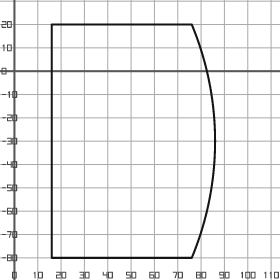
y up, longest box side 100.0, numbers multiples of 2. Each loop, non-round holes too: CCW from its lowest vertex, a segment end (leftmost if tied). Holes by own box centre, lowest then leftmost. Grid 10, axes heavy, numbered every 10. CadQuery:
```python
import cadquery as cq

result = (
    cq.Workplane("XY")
    .moveTo(16.0, -80.0)
    .lineTo(76.0, -80.0)
    .threePointArc((86.0, -30.0), (76.0, 20.0))
    .lineTo(16.0, 20.0)
    .close()
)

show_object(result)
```